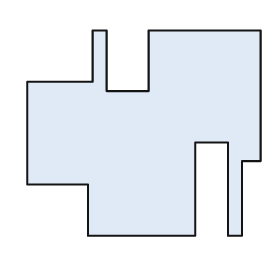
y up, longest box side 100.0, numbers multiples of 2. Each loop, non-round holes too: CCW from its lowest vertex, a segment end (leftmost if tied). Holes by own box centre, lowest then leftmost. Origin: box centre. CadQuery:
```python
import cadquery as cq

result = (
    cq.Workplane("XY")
    .moveTo(-24.0, -44.0)
    .lineTo(22.0, -44.0)
    .lineTo(22.0, -4.0)
    .lineTo(36.0, -4.0)
    .lineTo(36.0, -44.0)
    .lineTo(42.0, -44.0)
    .lineTo(42.0, -12.0)
    .lineTo(50.0, -12.0)
    .lineTo(50.0, 44.0)
    .lineTo(2.0, 44.0)
    .lineTo(2.0, 18.0)
    .lineTo(-16.0, 18.0)
    .lineTo(-16.0, 44.0)
    .lineTo(-22.0, 44.0)
    .lineTo(-22.0, 22.0)
    .lineTo(-50.0, 22.0)
    .lineTo(-50.0, -22.0)
    .lineTo(-24.0, -22.0)
    .close()
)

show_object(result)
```